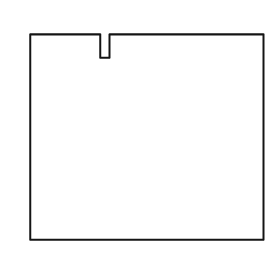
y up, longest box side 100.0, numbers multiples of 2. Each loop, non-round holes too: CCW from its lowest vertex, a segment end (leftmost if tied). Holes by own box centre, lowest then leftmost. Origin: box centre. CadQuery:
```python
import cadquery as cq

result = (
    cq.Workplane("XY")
    .moveTo(-50.0, -44.0)
    .lineTo(50.0, -44.0)
    .lineTo(50.0, 44.0)
    .lineTo(-16.0, 44.0)
    .lineTo(-16.0, 34.0)
    .lineTo(-20.0, 34.0)
    .lineTo(-20.0, 44.0)
    .lineTo(-50.0, 44.0)
    .close()
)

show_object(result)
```